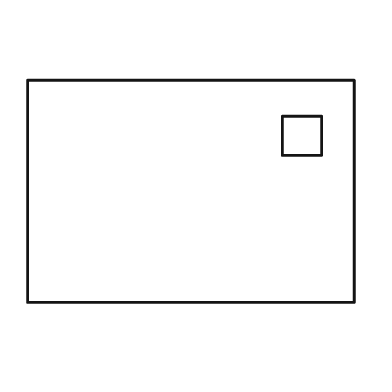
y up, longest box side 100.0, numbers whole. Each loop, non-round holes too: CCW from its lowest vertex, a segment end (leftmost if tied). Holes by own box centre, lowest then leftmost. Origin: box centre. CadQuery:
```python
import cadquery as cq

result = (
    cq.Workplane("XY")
    .moveTo(-50.0, -34.0)
    .lineTo(50.0, -34.0)
    .lineTo(50.0, 34.0)
    .lineTo(-50.0, 34.0)
    .close()
    .moveTo(28.0, 11.0)
    .lineTo(40.0, 11.0)
    .lineTo(40.0, 23.0)
    .lineTo(28.0, 23.0)
    .close()
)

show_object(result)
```